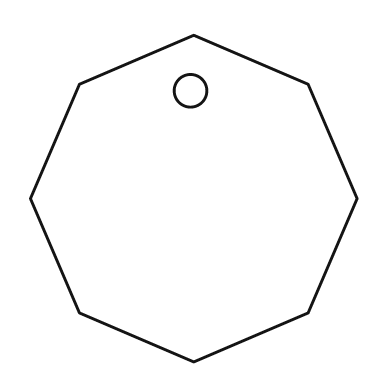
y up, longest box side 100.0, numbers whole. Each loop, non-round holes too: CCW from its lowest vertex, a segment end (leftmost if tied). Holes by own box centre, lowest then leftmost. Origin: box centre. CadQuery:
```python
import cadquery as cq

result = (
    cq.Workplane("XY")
    .moveTo(0.0, -50.0)
    .lineTo(35.0, -35.0)
    .lineTo(50.0, 0.0)
    .lineTo(35.0, 35.0)
    .lineTo(0.0, 50.0)
    .lineTo(-35.0, 35.0)
    .lineTo(-50.0, 0.0)
    .lineTo(-35.0, -35.0)
    .close()
    .moveTo(-1.0, 33.0)
    .circle(5.0)
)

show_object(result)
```